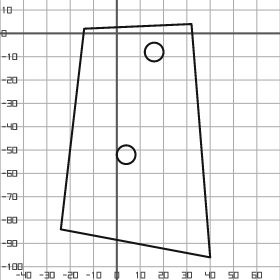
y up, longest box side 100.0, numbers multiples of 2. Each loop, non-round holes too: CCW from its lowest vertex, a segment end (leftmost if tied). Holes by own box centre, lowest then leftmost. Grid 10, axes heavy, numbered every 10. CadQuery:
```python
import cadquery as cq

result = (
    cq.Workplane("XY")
    .moveTo(40.0, -96.0)
    .lineTo(32.0, 4.0)
    .lineTo(-14.0, 2.0)
    .lineTo(-24.0, -84.0)
    .close()
    .moveTo(4.0, -52.0)
    .circle(4.0)
    .moveTo(16.0, -8.0)
    .circle(4.0)
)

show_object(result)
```